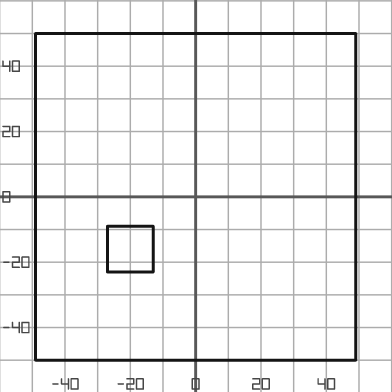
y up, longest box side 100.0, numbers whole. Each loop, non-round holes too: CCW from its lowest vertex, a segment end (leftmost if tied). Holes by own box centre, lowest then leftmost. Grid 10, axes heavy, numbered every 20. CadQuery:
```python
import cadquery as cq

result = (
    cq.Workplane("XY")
    .moveTo(-49.0, -50.0)
    .lineTo(49.0, -50.0)
    .lineTo(49.0, 50.0)
    .lineTo(-49.0, 50.0)
    .close()
    .moveTo(-27.0, -23.0)
    .lineTo(-13.0, -23.0)
    .lineTo(-13.0, -9.0)
    .lineTo(-27.0, -9.0)
    .close()
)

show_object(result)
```